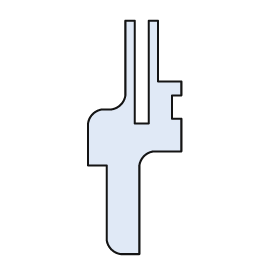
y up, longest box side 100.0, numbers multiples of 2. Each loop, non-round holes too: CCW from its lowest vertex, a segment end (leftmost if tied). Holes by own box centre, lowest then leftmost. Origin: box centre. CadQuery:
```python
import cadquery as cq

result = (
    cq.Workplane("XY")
    .moveTo(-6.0, -50.0)
    .lineTo(2.0, -50.0)
    .lineTo(2.0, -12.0)
    .threePointArc((4.0, -8.0), (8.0, -6.0))
    .lineTo(20.0, -6.0)
    .lineTo(20.0, 8.0)
    .lineTo(16.0, 8.0)
    .lineTo(16.0, 18.0)
    .lineTo(20.0, 18.0)
    .lineTo(20.0, 24.0)
    .lineTo(10.0, 24.0)
    .lineTo(10.0, 50.0)
    .lineTo(6.0, 50.0)
    .lineTo(6.0, 6.0)
    .lineTo(0.0, 6.0)
    .lineTo(0.0, 50.0)
    .lineTo(-4.0, 50.0)
    .lineTo(-4.0, 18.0)
    .threePointArc((-6.0, 14.0), (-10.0, 12.0))
    .lineTo(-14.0, 12.0)
    .threePointArc((-18.0, 10.0), (-20.0, 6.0))
    .lineTo(-20.0, -12.0)
    .lineTo(-12.0, -12.0)
    .lineTo(-12.0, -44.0)
    .threePointArc((-10.0, -48.0), (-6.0, -50.0))
    .close()
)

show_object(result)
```